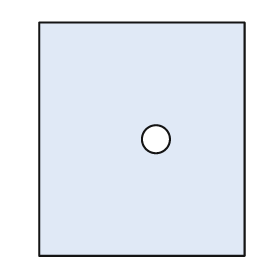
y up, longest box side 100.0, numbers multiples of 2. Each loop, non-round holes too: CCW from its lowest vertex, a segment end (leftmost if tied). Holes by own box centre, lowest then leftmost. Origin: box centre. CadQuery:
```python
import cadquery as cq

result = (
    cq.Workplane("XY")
    .moveTo(-44.0, -50.0)
    .lineTo(44.0, -50.0)
    .lineTo(44.0, 50.0)
    .lineTo(-44.0, 50.0)
    .close()
    .moveTo(6.0, 0.0)
    .circle(6.0)
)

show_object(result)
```